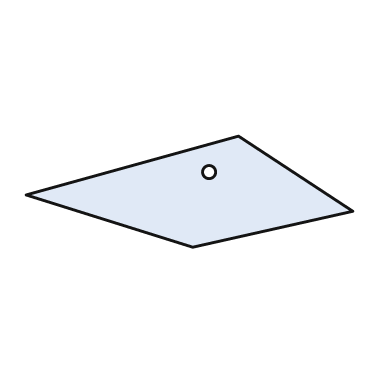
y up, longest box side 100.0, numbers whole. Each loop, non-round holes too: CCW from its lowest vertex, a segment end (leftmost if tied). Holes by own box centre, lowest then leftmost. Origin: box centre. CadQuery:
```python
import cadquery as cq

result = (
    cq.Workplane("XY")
    .moveTo(1.0, -17.0)
    .lineTo(50.0, -6.0)
    .lineTo(15.0, 17.0)
    .lineTo(-50.0, -1.0)
    .close()
    .moveTo(6.0, 6.0)
    .circle(2.0)
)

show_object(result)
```